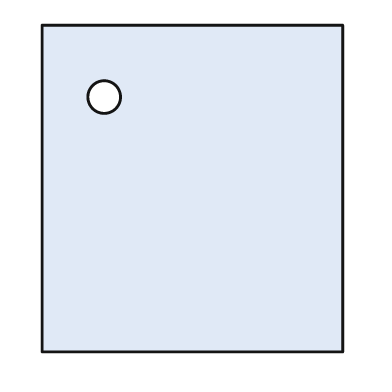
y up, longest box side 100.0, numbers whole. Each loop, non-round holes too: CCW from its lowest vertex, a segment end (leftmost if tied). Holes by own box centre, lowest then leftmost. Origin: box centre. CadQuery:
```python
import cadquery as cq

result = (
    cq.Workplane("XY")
    .moveTo(-46.0, -50.0)
    .lineTo(46.0, -50.0)
    .lineTo(46.0, 50.0)
    .lineTo(-46.0, 50.0)
    .close()
    .moveTo(-27.0, 28.0)
    .circle(5.0)
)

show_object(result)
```